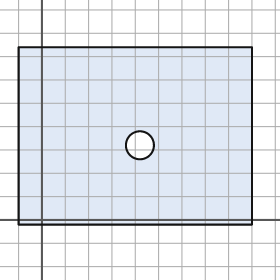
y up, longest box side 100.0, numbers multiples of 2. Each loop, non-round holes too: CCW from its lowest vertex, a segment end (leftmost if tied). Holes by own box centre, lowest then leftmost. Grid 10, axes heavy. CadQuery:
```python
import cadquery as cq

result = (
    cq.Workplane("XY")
    .moveTo(-10.0, -2.0)
    .lineTo(90.0, -2.0)
    .lineTo(90.0, 74.0)
    .lineTo(-10.0, 74.0)
    .close()
    .moveTo(42.0, 32.0)
    .circle(6.0)
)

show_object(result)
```